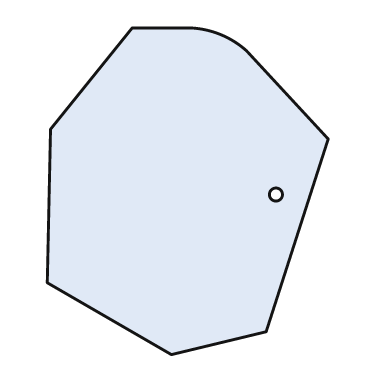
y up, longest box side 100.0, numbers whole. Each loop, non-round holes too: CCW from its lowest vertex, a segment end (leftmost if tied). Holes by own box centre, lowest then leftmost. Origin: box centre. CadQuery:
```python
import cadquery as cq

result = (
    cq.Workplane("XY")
    .moveTo(-5.0, -50.0)
    .lineTo(24.0, -43.0)
    .lineTo(43.0, 16.0)
    .lineTo(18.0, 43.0)
    .threePointArc((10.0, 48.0), (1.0, 50.0))
    .lineTo(-17.0, 50.0)
    .lineTo(-42.0, 19.0)
    .lineTo(-43.0, -28.0)
    .close()
    .moveTo(27.0, -1.0)
    .circle(2.0)
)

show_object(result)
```